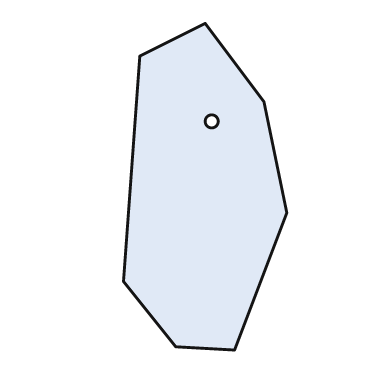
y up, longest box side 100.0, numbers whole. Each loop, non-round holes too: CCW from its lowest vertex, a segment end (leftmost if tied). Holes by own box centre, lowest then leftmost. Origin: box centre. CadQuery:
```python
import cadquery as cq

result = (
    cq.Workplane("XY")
    .moveTo(9.0, -50.0)
    .lineTo(25.0, -8.0)
    .lineTo(18.0, 26.0)
    .lineTo(0.0, 50.0)
    .lineTo(-20.0, 40.0)
    .lineTo(-25.0, -29.0)
    .lineTo(-9.0, -49.0)
    .close()
    .moveTo(2.0, 20.0)
    .circle(2.0)
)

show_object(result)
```